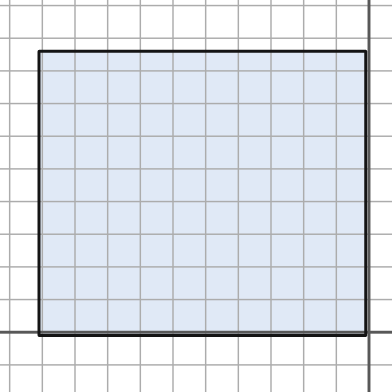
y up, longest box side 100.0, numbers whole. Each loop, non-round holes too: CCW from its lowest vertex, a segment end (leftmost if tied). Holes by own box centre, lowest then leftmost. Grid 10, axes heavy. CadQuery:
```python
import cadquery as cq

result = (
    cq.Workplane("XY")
    .moveTo(-101.0, -1.0)
    .lineTo(-1.0, -1.0)
    .lineTo(-1.0, 86.0)
    .lineTo(-101.0, 86.0)
    .close()
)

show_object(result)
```